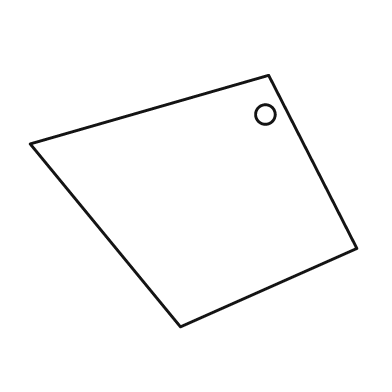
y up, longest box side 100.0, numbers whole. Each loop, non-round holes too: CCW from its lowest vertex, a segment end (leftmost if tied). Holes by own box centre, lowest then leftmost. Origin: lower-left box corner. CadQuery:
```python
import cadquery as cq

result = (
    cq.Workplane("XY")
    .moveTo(46.0, 0.0)
    .lineTo(100.0, 24.0)
    .lineTo(73.0, 77.0)
    .lineTo(0.0, 56.0)
    .close()
    .moveTo(72.0, 65.0)
    .circle(3.0)
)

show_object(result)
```